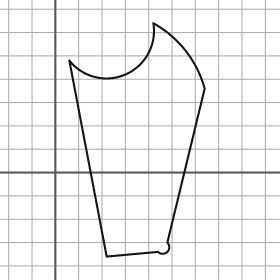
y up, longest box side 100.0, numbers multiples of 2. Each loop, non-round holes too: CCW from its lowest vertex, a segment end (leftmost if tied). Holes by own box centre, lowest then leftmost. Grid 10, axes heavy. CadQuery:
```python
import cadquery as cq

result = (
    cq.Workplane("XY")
    .moveTo(22.0, -36.0)
    .lineTo(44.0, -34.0)
    .threePointArc((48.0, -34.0), (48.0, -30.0))
    .lineTo(64.0, 36.0)
    .threePointArc((56.0, 52.0), (42.0, 64.0))
    .threePointArc((30.0, 42.0), (6.0, 48.0))
    .close()
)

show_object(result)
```